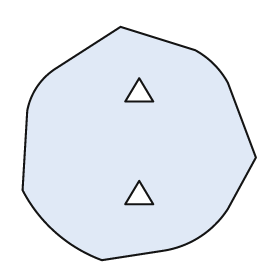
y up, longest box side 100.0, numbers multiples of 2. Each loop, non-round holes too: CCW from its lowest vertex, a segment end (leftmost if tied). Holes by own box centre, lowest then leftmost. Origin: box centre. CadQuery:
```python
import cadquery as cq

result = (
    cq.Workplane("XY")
    .moveTo(-16.0, -50.0)
    .lineTo(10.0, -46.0)
    .threePointArc((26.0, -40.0), (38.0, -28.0))
    .lineTo(50.0, -6.0)
    .lineTo(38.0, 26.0)
    .threePointArc((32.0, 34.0), (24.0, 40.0))
    .lineTo(-8.0, 50.0)
    .lineTo(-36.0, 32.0)
    .threePointArc((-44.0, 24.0), (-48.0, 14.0))
    .lineTo(-50.0, -20.0)
    .threePointArc((-36.0, -38.0), (-16.0, -50.0))
    .close()
    .moveTo(-6.0, -26.0)
    .lineTo(6.0, -26.0)
    .lineTo(0.0, -16.0)
    .close()
    .moveTo(-6.0, 18.0)
    .lineTo(6.0, 18.0)
    .lineTo(0.0, 28.0)
    .close()
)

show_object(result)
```